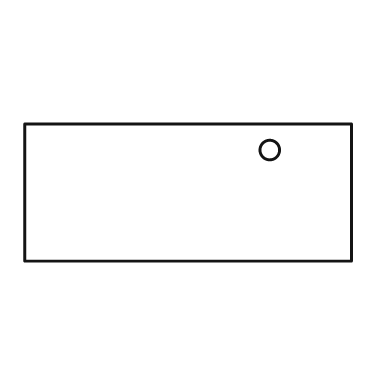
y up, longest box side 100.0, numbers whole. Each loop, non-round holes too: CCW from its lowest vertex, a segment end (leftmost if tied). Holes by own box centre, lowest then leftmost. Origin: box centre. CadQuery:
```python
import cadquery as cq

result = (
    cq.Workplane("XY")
    .moveTo(-50.0, -21.0)
    .lineTo(50.0, -21.0)
    .lineTo(50.0, 21.0)
    .lineTo(-50.0, 21.0)
    .close()
    .moveTo(25.0, 13.0)
    .circle(3.0)
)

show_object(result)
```